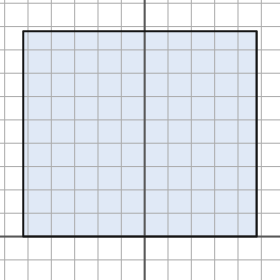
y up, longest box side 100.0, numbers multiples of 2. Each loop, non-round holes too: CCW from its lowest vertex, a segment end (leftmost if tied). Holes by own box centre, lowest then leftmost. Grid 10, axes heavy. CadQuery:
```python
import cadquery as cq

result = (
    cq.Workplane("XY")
    .moveTo(-52.0, 0.0)
    .lineTo(48.0, 0.0)
    .lineTo(48.0, 88.0)
    .lineTo(-52.0, 88.0)
    .close()
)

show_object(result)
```